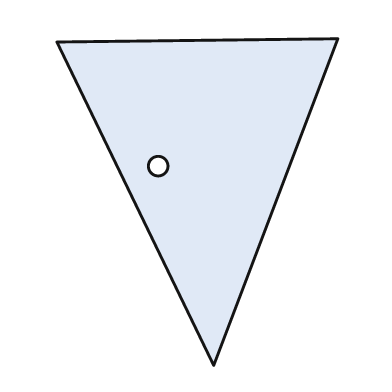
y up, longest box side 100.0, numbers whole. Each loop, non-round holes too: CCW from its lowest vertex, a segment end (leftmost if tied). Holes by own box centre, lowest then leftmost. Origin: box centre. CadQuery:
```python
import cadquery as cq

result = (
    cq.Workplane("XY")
    .moveTo(5.0, -50.0)
    .lineTo(43.0, 50.0)
    .lineTo(-43.0, 49.0)
    .close()
    .moveTo(-12.0, 11.0)
    .circle(3.0)
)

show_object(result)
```